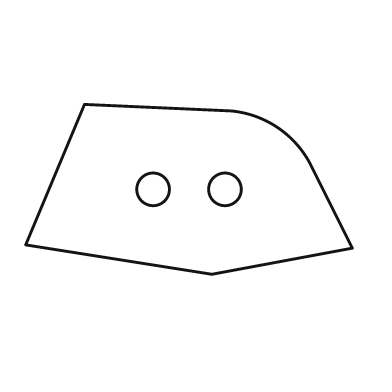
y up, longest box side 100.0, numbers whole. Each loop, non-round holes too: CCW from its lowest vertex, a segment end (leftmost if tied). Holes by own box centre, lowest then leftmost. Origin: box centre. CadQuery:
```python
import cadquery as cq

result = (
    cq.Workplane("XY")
    .moveTo(7.0, -26.0)
    .lineTo(50.0, -18.0)
    .lineTo(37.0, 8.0)
    .threePointArc((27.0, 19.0), (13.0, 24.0))
    .lineTo(-32.0, 26.0)
    .lineTo(-50.0, -17.0)
    .close()
    .moveTo(-11.0, 0.0)
    .circle(5.0)
    .moveTo(11.0, 0.0)
    .circle(5.0)
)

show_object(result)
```